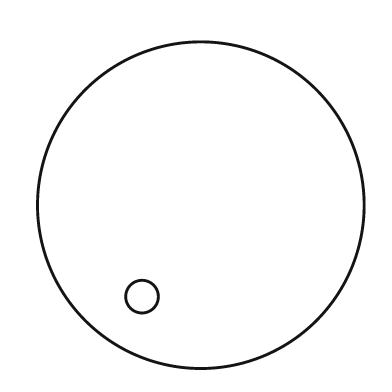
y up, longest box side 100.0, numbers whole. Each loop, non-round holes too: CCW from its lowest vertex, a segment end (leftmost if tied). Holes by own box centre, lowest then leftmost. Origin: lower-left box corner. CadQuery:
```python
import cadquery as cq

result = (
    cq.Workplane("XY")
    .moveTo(50.0, 50.0)
    .circle(50.0)
    .moveTo(32.0, 22.0)
    .circle(5.0)
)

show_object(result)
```